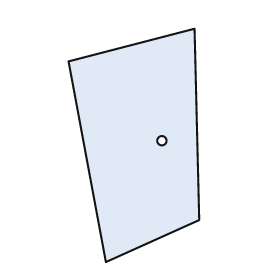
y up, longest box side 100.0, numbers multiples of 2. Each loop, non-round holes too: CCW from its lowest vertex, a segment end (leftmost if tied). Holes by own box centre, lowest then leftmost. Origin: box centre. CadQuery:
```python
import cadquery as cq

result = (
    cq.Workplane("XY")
    .moveTo(-12.0, -50.0)
    .lineTo(28.0, -32.0)
    .lineTo(26.0, 50.0)
    .lineTo(-28.0, 36.0)
    .close()
    .moveTo(12.0, 2.0)
    .circle(2.0)
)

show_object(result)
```